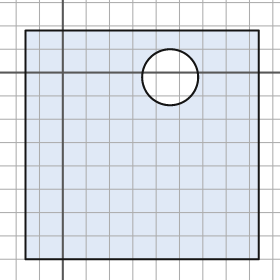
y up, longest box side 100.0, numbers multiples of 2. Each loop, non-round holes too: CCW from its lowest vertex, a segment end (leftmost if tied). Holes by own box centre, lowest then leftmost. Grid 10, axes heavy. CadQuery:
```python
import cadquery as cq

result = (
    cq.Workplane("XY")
    .moveTo(-16.0, -80.0)
    .lineTo(84.0, -80.0)
    .lineTo(84.0, 18.0)
    .lineTo(-16.0, 18.0)
    .close()
    .moveTo(46.0, -2.0)
    .circle(12.0)
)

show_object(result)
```